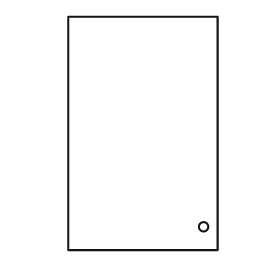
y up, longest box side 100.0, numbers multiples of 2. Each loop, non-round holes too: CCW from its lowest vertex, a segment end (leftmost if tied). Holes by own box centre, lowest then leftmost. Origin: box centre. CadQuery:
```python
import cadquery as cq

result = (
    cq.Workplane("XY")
    .moveTo(-32.0, -50.0)
    .lineTo(32.0, -50.0)
    .lineTo(32.0, 50.0)
    .lineTo(-32.0, 50.0)
    .close()
    .moveTo(26.0, -40.0)
    .circle(2.0)
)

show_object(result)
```